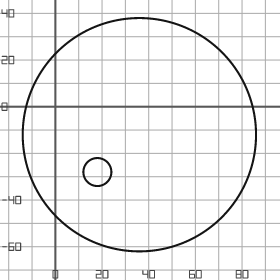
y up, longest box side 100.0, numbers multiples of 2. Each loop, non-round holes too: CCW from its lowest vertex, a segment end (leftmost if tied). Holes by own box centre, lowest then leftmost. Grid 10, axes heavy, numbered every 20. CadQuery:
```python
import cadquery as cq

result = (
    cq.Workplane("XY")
    .moveTo(36.0, -12.0)
    .circle(50.0)
    .moveTo(18.0, -28.0)
    .circle(6.0)
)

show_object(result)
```